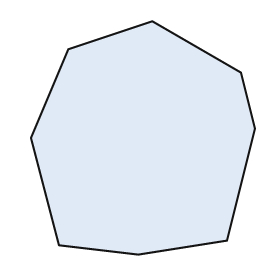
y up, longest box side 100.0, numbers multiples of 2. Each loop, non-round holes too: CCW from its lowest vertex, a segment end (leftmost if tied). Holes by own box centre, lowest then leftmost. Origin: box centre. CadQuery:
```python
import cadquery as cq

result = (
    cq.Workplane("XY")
    .moveTo(-2.0, -50.0)
    .lineTo(36.0, -44.0)
    .lineTo(48.0, 4.0)
    .lineTo(42.0, 28.0)
    .lineTo(4.0, 50.0)
    .lineTo(-32.0, 38.0)
    .lineTo(-48.0, 0.0)
    .lineTo(-36.0, -46.0)
    .close()
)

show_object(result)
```